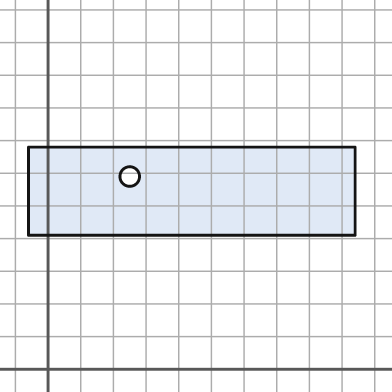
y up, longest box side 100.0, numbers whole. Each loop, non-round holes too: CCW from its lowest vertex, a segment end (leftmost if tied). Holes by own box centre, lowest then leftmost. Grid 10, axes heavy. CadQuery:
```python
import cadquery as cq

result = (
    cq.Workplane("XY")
    .moveTo(-6.0, 41.0)
    .lineTo(94.0, 41.0)
    .lineTo(94.0, 68.0)
    .lineTo(-6.0, 68.0)
    .close()
    .moveTo(25.0, 59.0)
    .circle(3.0)
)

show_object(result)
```